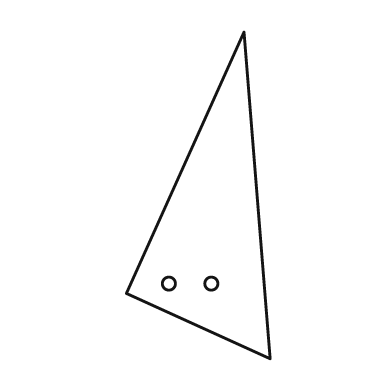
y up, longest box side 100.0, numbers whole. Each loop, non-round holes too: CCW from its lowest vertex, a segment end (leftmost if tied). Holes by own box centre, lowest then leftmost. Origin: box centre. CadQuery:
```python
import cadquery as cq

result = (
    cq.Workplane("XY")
    .moveTo(22.0, -50.0)
    .lineTo(14.0, 50.0)
    .lineTo(-22.0, -30.0)
    .close()
    .moveTo(-9.0, -27.0)
    .circle(2.0)
    .moveTo(4.0, -27.0)
    .circle(2.0)
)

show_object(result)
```